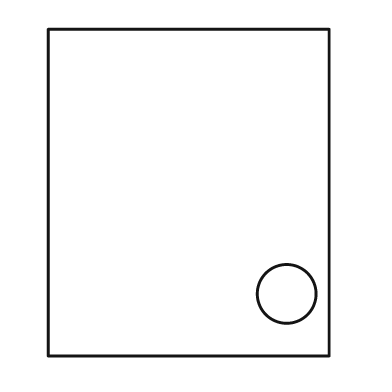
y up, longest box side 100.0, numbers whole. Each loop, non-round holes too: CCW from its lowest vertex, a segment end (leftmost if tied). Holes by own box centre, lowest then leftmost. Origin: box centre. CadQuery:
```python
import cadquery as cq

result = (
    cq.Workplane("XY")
    .moveTo(-43.0, -50.0)
    .lineTo(43.0, -50.0)
    .lineTo(43.0, 50.0)
    .lineTo(-43.0, 50.0)
    .close()
    .moveTo(30.0, -31.0)
    .circle(9.0)
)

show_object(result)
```